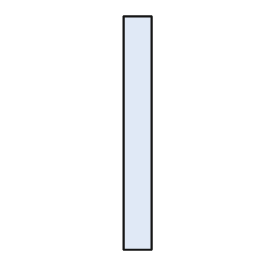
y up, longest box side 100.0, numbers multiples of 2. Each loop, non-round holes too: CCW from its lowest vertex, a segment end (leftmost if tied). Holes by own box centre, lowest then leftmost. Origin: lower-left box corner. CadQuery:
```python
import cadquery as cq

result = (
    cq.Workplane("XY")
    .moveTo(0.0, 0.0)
    .lineTo(12.0, 0.0)
    .lineTo(12.0, 100.0)
    .lineTo(0.0, 100.0)
    .close()
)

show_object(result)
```